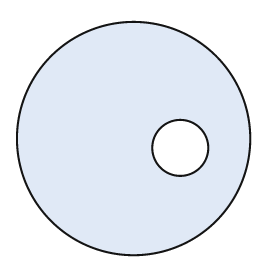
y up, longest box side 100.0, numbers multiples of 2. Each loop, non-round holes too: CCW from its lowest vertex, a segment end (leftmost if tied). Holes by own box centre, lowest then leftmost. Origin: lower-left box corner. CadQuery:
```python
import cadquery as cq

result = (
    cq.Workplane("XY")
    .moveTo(50.0, 50.0)
    .circle(50.0)
    .moveTo(70.0, 46.0)
    .circle(12.0)
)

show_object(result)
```